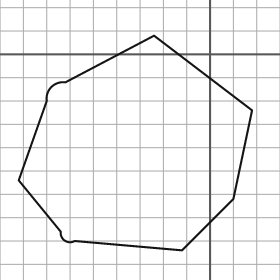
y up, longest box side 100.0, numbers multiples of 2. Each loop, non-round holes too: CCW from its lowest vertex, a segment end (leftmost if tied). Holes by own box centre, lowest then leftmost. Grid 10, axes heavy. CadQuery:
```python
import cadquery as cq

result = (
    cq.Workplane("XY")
    .moveTo(-12.0, -84.0)
    .lineTo(10.0, -62.0)
    .lineTo(18.0, -24.0)
    .lineTo(-24.0, 8.0)
    .lineTo(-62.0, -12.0)
    .threePointArc((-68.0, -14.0), (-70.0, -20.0))
    .lineTo(-82.0, -54.0)
    .lineTo(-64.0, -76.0)
    .threePointArc((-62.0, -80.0), (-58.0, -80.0))
    .close()
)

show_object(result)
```